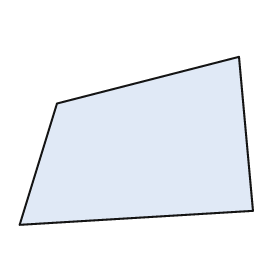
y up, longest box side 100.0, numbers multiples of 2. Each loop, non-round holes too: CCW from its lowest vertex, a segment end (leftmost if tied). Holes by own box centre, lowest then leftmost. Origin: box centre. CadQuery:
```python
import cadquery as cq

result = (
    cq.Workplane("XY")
    .moveTo(-50.0, -36.0)
    .lineTo(50.0, -30.0)
    .lineTo(44.0, 36.0)
    .lineTo(-34.0, 16.0)
    .close()
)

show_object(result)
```